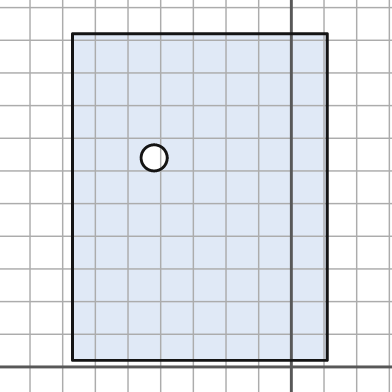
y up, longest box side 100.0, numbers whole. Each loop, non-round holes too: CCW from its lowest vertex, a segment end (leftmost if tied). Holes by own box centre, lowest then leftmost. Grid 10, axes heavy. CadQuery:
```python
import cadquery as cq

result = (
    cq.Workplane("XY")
    .moveTo(-67.0, 2.0)
    .lineTo(11.0, 2.0)
    .lineTo(11.0, 102.0)
    .lineTo(-67.0, 102.0)
    .close()
    .moveTo(-42.0, 64.0)
    .circle(4.0)
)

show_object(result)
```